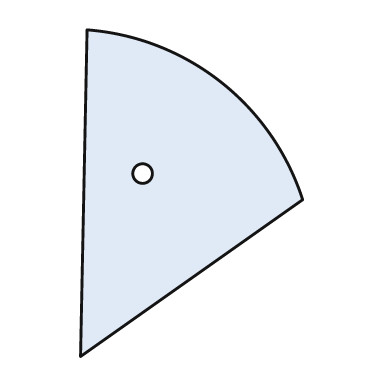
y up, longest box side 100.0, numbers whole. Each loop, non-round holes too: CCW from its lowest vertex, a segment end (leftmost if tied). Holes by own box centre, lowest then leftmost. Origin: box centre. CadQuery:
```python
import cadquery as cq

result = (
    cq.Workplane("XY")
    .moveTo(-34.0, -50.0)
    .lineTo(34.0, -2.0)
    .threePointArc((9.0, 34.0), (-32.0, 50.0))
    .close()
    .moveTo(-15.0, 6.0)
    .circle(3.0)
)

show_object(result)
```